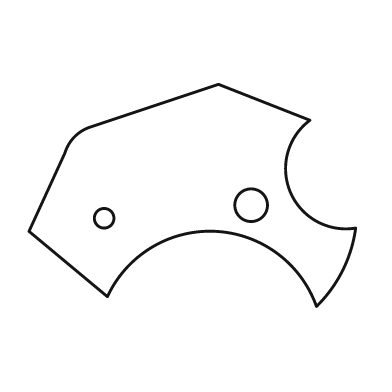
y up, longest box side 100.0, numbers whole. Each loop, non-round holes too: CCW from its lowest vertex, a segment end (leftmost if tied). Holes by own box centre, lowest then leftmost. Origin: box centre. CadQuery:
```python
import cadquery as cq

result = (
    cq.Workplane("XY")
    .moveTo(38.0, -34.0)
    .threePointArc((46.0, -23.0), (50.0, -10.0))
    .threePointArc((30.0, 1.0), (36.0, 23.0))
    .lineTo(8.0, 34.0)
    .lineTo(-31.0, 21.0)
    .threePointArc((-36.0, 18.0), (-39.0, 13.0))
    .lineTo(-50.0, -11.0)
    .lineTo(-26.0, -31.0)
    .threePointArc((7.0, -11.0), (38.0, -34.0))
    .close()
    .moveTo(-27.0, -7.0)
    .circle(3.0)
    .moveTo(18.0, -3.0)
    .circle(5.0)
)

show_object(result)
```